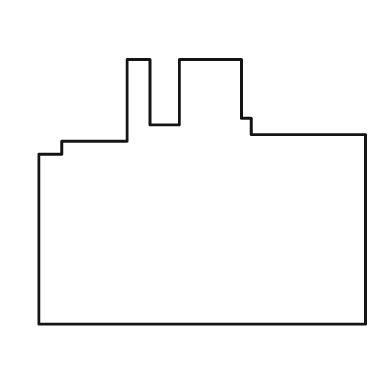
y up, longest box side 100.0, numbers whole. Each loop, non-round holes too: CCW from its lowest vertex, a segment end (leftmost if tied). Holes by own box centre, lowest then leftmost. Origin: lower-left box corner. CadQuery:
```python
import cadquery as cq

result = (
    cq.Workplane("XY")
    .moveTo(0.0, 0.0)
    .lineTo(100.0, 0.0)
    .lineTo(100.0, 58.0)
    .lineTo(65.0, 58.0)
    .lineTo(65.0, 63.0)
    .lineTo(62.0, 63.0)
    .lineTo(62.0, 81.0)
    .lineTo(43.0, 81.0)
    .lineTo(43.0, 61.0)
    .lineTo(34.0, 61.0)
    .lineTo(34.0, 81.0)
    .lineTo(27.0, 81.0)
    .lineTo(27.0, 56.0)
    .lineTo(7.0, 56.0)
    .lineTo(7.0, 52.0)
    .lineTo(0.0, 52.0)
    .close()
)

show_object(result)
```